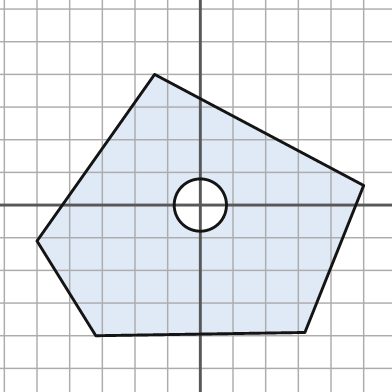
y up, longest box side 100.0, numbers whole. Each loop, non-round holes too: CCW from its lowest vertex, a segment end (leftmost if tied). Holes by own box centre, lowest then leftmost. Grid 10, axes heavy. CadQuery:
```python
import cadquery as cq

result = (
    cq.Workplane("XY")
    .moveTo(-32.0, -40.0)
    .lineTo(32.0, -39.0)
    .lineTo(50.0, 6.0)
    .lineTo(-14.0, 40.0)
    .lineTo(-50.0, -11.0)
    .close()
    .moveTo(0.0, 0.0)
    .circle(8.0)
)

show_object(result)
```